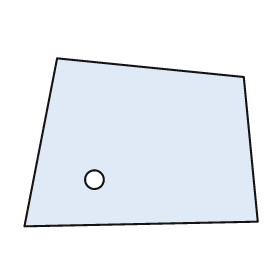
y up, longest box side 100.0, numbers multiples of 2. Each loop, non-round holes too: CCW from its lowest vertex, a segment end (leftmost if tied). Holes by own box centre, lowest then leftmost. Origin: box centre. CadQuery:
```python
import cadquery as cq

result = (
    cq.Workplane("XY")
    .moveTo(-50.0, -36.0)
    .lineTo(50.0, -34.0)
    .lineTo(44.0, 28.0)
    .lineTo(-36.0, 36.0)
    .close()
    .moveTo(-20.0, -16.0)
    .circle(4.0)
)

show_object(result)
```